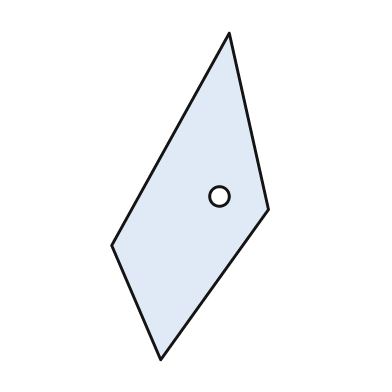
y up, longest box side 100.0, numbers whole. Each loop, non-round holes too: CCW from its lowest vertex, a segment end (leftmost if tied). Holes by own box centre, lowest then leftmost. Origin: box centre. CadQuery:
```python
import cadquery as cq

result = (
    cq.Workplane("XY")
    .moveTo(-9.0, -50.0)
    .lineTo(24.0, -4.0)
    .lineTo(12.0, 50.0)
    .lineTo(-24.0, -15.0)
    .close()
    .moveTo(9.0, 0.0)
    .circle(3.0)
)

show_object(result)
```